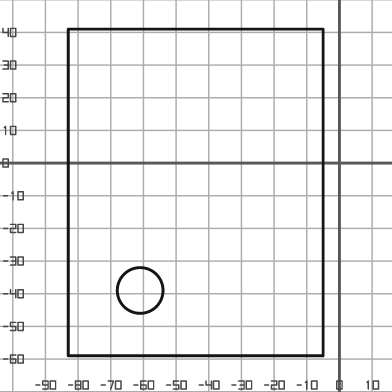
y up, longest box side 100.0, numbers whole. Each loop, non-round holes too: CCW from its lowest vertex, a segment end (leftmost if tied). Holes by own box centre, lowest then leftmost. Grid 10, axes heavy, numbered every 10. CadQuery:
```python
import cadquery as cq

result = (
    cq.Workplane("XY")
    .moveTo(-83.0, -59.0)
    .lineTo(-5.0, -59.0)
    .lineTo(-5.0, 41.0)
    .lineTo(-83.0, 41.0)
    .close()
    .moveTo(-61.0, -39.0)
    .circle(7.0)
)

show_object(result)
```